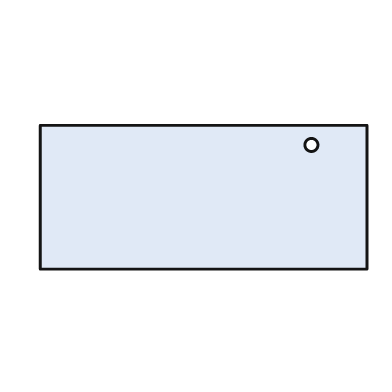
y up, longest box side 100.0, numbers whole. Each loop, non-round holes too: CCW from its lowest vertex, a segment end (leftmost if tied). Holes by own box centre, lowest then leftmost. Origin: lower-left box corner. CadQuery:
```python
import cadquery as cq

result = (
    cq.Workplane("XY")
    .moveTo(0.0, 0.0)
    .lineTo(100.0, 0.0)
    .lineTo(100.0, 44.0)
    .lineTo(0.0, 44.0)
    .close()
    .moveTo(83.0, 38.0)
    .circle(2.0)
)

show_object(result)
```